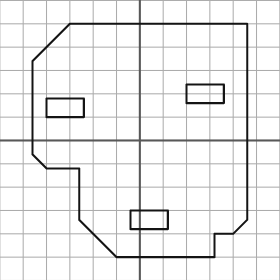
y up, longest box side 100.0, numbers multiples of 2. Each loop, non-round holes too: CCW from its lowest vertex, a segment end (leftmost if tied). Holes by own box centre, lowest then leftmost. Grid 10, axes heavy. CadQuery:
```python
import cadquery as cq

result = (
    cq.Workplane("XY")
    .moveTo(-10.0, -50.0)
    .lineTo(32.0, -50.0)
    .lineTo(32.0, -40.0)
    .lineTo(40.0, -40.0)
    .lineTo(46.0, -34.0)
    .lineTo(46.0, 50.0)
    .lineTo(-30.0, 50.0)
    .lineTo(-46.0, 34.0)
    .lineTo(-46.0, -6.0)
    .lineTo(-40.0, -12.0)
    .lineTo(-26.0, -12.0)
    .lineTo(-26.0, -34.0)
    .close()
    .moveTo(-4.0, -38.0)
    .lineTo(12.0, -38.0)
    .lineTo(12.0, -30.0)
    .lineTo(-4.0, -30.0)
    .close()
    .moveTo(-40.0, 10.0)
    .lineTo(-24.0, 10.0)
    .lineTo(-24.0, 18.0)
    .lineTo(-40.0, 18.0)
    .close()
    .moveTo(20.0, 16.0)
    .lineTo(36.0, 16.0)
    .lineTo(36.0, 24.0)
    .lineTo(20.0, 24.0)
    .close()
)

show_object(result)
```